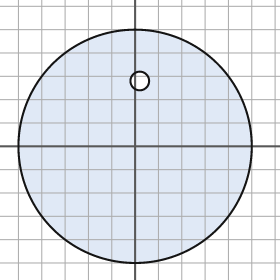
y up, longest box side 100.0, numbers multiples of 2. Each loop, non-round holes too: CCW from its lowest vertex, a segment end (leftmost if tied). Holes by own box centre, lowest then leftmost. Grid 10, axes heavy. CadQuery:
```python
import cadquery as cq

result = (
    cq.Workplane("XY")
    .moveTo(0.0, 0.0)
    .circle(50.0)
    .moveTo(2.0, 28.0)
    .circle(4.0)
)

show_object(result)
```